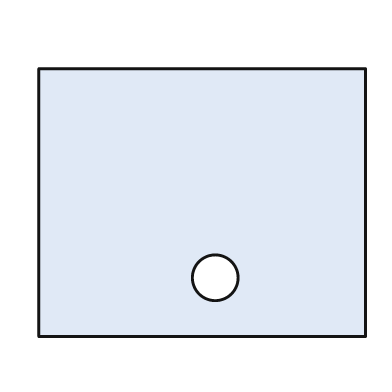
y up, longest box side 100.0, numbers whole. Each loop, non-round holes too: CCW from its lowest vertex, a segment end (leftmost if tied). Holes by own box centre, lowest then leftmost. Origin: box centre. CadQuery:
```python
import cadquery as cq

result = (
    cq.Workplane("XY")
    .moveTo(-50.0, -41.0)
    .lineTo(50.0, -41.0)
    .lineTo(50.0, 41.0)
    .lineTo(-50.0, 41.0)
    .close()
    .moveTo(4.0, -23.0)
    .circle(7.0)
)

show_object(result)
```